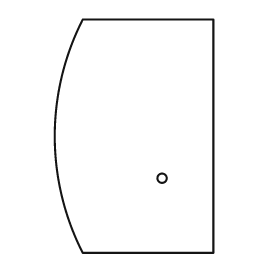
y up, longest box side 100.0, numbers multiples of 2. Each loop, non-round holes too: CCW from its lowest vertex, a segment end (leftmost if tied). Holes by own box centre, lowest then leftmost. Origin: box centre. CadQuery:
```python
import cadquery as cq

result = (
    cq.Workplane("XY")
    .moveTo(-22.0, -50.0)
    .lineTo(34.0, -50.0)
    .lineTo(34.0, 50.0)
    .lineTo(-22.0, 50.0)
    .threePointArc((-34.0, 0.0), (-22.0, -50.0))
    .close()
    .moveTo(12.0, -18.0)
    .circle(2.0)
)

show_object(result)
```